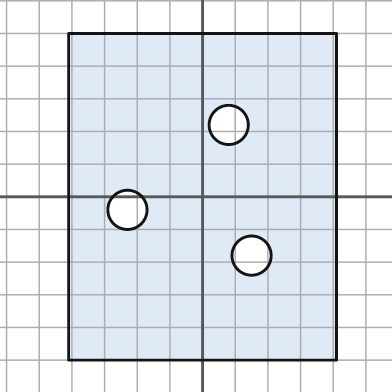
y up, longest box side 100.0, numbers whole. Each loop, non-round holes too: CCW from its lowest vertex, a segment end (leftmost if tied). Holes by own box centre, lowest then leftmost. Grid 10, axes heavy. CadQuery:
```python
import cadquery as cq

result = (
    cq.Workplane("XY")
    .moveTo(-41.0, -50.0)
    .lineTo(41.0, -50.0)
    .lineTo(41.0, 50.0)
    .lineTo(-41.0, 50.0)
    .close()
    .moveTo(15.0, -18.0)
    .circle(6.0)
    .moveTo(-23.0, -4.0)
    .circle(6.0)
    .moveTo(8.0, 22.0)
    .circle(6.0)
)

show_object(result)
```